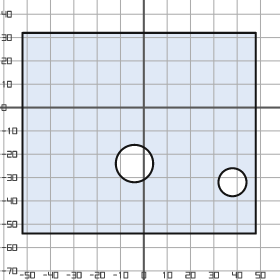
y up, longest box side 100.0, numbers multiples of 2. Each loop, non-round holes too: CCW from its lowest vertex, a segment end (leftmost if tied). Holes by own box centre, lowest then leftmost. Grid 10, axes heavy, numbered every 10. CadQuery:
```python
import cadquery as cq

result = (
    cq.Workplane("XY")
    .moveTo(-52.0, -54.0)
    .lineTo(48.0, -54.0)
    .lineTo(48.0, 32.0)
    .lineTo(-52.0, 32.0)
    .close()
    .moveTo(38.0, -32.0)
    .circle(6.0)
    .moveTo(-4.0, -24.0)
    .circle(8.0)
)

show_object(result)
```